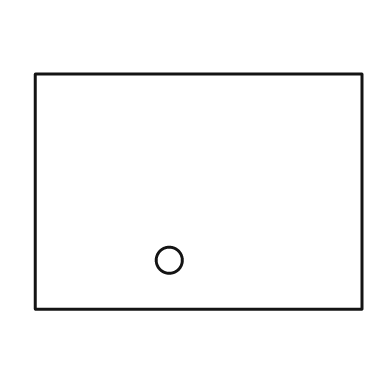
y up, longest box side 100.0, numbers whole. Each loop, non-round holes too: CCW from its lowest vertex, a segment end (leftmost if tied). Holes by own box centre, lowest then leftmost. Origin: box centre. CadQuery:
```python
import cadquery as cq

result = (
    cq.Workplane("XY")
    .moveTo(-50.0, -36.0)
    .lineTo(50.0, -36.0)
    .lineTo(50.0, 36.0)
    .lineTo(-50.0, 36.0)
    .close()
    .moveTo(-9.0, -21.0)
    .circle(4.0)
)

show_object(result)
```